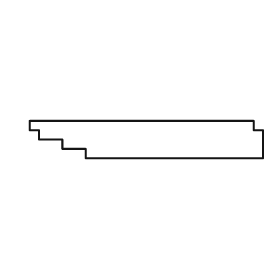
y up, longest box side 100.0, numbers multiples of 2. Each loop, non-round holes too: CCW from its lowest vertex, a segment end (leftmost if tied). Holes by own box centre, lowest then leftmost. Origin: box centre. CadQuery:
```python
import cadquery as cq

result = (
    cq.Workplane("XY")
    .moveTo(-26.0, -8.0)
    .lineTo(50.0, -8.0)
    .lineTo(50.0, 4.0)
    .lineTo(46.0, 4.0)
    .lineTo(46.0, 8.0)
    .lineTo(-50.0, 8.0)
    .lineTo(-50.0, 4.0)
    .lineTo(-46.0, 4.0)
    .lineTo(-46.0, 0.0)
    .lineTo(-36.0, 0.0)
    .lineTo(-36.0, -4.0)
    .lineTo(-26.0, -4.0)
    .close()
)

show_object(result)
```